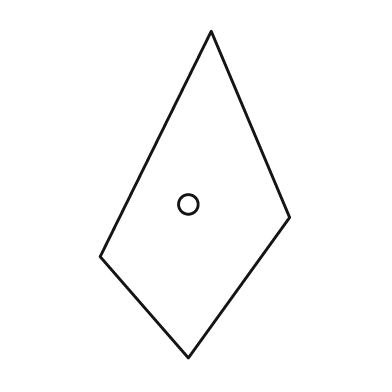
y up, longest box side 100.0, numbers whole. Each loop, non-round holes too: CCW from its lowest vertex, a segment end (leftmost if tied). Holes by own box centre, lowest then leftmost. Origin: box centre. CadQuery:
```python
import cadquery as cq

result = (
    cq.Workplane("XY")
    .moveTo(-2.0, -50.0)
    .lineTo(29.0, -7.0)
    .lineTo(5.0, 50.0)
    .lineTo(-29.0, -19.0)
    .close()
    .moveTo(-2.0, -3.0)
    .circle(3.0)
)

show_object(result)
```